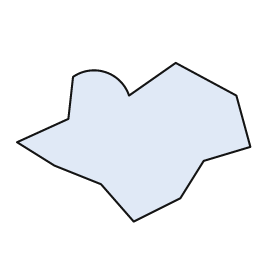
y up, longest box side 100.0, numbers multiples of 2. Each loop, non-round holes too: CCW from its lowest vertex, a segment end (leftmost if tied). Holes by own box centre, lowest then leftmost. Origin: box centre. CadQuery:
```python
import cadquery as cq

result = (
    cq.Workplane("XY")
    .moveTo(0.0, -34.0)
    .lineTo(20.0, -24.0)
    .lineTo(30.0, -8.0)
    .lineTo(50.0, -2.0)
    .lineTo(44.0, 20.0)
    .lineTo(18.0, 34.0)
    .lineTo(-2.0, 20.0)
    .threePointArc((-12.0, 30.0), (-26.0, 28.0))
    .lineTo(-28.0, 10.0)
    .lineTo(-50.0, 0.0)
    .lineTo(-34.0, -10.0)
    .lineTo(-14.0, -18.0)
    .close()
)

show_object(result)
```